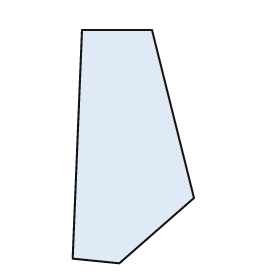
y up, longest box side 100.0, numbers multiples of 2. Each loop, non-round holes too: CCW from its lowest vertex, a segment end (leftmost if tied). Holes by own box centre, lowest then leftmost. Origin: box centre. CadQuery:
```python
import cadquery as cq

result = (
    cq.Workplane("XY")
    .moveTo(-6.0, -50.0)
    .lineTo(26.0, -22.0)
    .lineTo(8.0, 50.0)
    .lineTo(-22.0, 50.0)
    .lineTo(-26.0, -48.0)
    .close()
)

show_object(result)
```